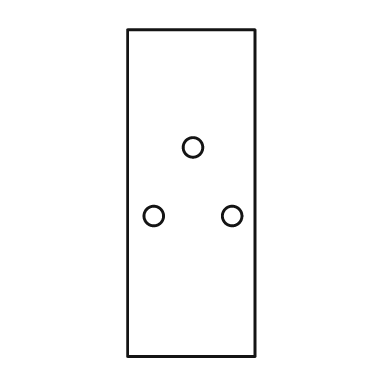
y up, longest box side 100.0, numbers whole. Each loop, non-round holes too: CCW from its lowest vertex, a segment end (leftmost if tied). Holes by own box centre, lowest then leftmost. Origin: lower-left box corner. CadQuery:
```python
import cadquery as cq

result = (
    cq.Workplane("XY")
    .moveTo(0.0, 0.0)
    .lineTo(39.0, 0.0)
    .lineTo(39.0, 100.0)
    .lineTo(0.0, 100.0)
    .close()
    .moveTo(8.0, 43.0)
    .circle(3.0)
    .moveTo(32.0, 43.0)
    .circle(3.0)
    .moveTo(20.0, 64.0)
    .circle(3.0)
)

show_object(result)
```